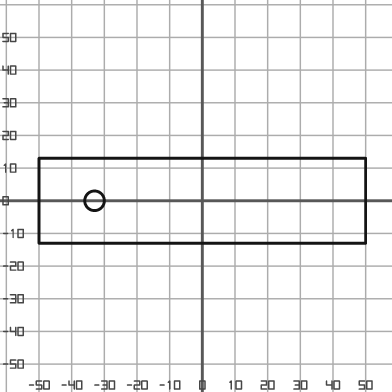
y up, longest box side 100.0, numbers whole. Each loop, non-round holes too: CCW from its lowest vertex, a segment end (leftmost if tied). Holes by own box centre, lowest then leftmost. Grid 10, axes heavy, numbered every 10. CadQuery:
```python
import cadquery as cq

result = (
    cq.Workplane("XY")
    .moveTo(-50.0, -13.0)
    .lineTo(50.0, -13.0)
    .lineTo(50.0, 13.0)
    .lineTo(-50.0, 13.0)
    .close()
    .moveTo(-33.0, 0.0)
    .circle(3.0)
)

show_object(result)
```